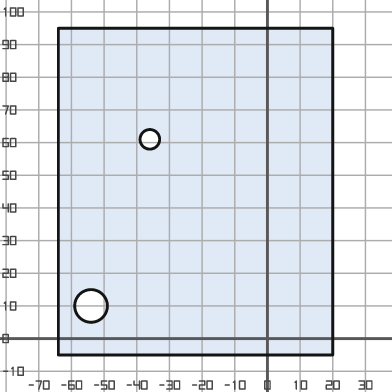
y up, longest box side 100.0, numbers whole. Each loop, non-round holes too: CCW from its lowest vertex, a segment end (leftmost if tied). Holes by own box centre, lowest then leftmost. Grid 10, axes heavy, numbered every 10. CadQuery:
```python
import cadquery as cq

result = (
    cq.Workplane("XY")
    .moveTo(-64.0, -5.0)
    .lineTo(20.0, -5.0)
    .lineTo(20.0, 95.0)
    .lineTo(-64.0, 95.0)
    .close()
    .moveTo(-54.0, 10.0)
    .circle(5.0)
    .moveTo(-36.0, 61.0)
    .circle(3.0)
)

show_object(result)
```